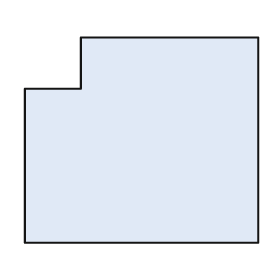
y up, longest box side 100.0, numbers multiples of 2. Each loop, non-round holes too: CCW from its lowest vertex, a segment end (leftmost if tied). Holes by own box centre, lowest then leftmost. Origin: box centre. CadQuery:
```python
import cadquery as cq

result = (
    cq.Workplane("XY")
    .moveTo(-50.0, -44.0)
    .lineTo(50.0, -44.0)
    .lineTo(50.0, 44.0)
    .lineTo(-26.0, 44.0)
    .lineTo(-26.0, 22.0)
    .lineTo(-50.0, 22.0)
    .close()
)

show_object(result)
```